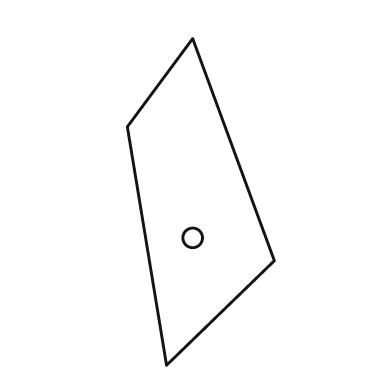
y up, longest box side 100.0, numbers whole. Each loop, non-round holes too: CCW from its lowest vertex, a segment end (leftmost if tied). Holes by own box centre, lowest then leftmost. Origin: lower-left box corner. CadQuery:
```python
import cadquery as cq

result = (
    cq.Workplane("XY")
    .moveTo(12.0, 0.0)
    .lineTo(45.0, 32.0)
    .lineTo(20.0, 100.0)
    .lineTo(0.0, 73.0)
    .close()
    .moveTo(20.0, 39.0)
    .circle(3.0)
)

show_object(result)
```